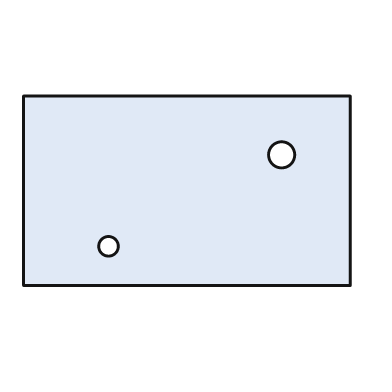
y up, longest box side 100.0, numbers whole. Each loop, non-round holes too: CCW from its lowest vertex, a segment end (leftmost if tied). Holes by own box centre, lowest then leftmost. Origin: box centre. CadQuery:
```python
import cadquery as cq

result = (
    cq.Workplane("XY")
    .moveTo(-50.0, -29.0)
    .lineTo(50.0, -29.0)
    .lineTo(50.0, 29.0)
    .lineTo(-50.0, 29.0)
    .close()
    .moveTo(-24.0, -17.0)
    .circle(3.0)
    .moveTo(29.0, 11.0)
    .circle(4.0)
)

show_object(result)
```